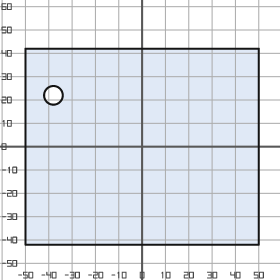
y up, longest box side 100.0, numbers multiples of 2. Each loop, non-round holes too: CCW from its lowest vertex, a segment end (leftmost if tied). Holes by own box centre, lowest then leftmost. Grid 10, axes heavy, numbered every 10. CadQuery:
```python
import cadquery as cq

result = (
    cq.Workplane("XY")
    .moveTo(-50.0, -42.0)
    .lineTo(50.0, -42.0)
    .lineTo(50.0, 42.0)
    .lineTo(-50.0, 42.0)
    .close()
    .moveTo(-38.0, 22.0)
    .circle(4.0)
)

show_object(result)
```